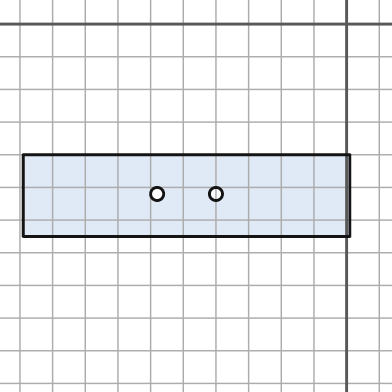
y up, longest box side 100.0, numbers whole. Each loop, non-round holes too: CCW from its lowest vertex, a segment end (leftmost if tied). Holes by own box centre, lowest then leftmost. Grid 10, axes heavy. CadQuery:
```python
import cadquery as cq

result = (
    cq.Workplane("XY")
    .moveTo(-99.0, -65.0)
    .lineTo(1.0, -65.0)
    .lineTo(1.0, -40.0)
    .lineTo(-99.0, -40.0)
    .close()
    .moveTo(-58.0, -52.0)
    .circle(2.0)
    .moveTo(-40.0, -52.0)
    .circle(2.0)
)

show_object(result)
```